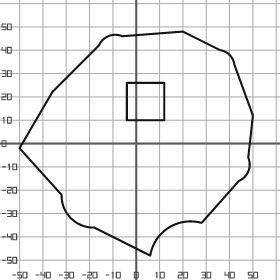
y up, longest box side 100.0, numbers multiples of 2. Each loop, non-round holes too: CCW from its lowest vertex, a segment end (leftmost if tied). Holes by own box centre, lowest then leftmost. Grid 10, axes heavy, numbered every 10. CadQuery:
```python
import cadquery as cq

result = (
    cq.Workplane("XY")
    .moveTo(6.0, -48.0)
    .threePointArc((14.0, -36.0), (28.0, -34.0))
    .lineTo(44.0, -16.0)
    .threePointArc((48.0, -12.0), (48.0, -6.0))
    .lineTo(50.0, 12.0)
    .lineTo(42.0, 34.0)
    .threePointArc((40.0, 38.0), (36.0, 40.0))
    .lineTo(20.0, 48.0)
    .lineTo(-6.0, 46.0)
    .threePointArc((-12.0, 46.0), (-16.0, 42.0))
    .lineTo(-36.0, 22.0)
    .lineTo(-50.0, -2.0)
    .lineTo(-32.0, -22.0)
    .threePointArc((-28.0, -32.0), (-18.0, -36.0))
    .close()
    .moveTo(-4.0, 10.0)
    .lineTo(12.0, 10.0)
    .lineTo(12.0, 26.0)
    .lineTo(-4.0, 26.0)
    .close()
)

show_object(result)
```